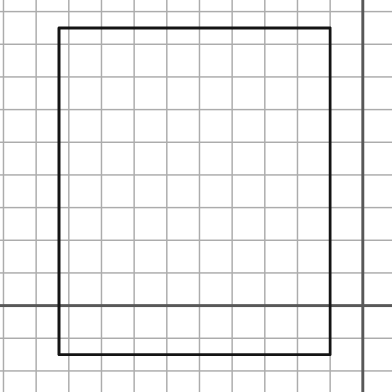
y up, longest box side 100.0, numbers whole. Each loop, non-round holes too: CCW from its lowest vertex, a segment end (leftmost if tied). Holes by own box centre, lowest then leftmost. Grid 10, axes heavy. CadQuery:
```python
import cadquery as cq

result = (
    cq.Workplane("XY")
    .moveTo(-93.0, -15.0)
    .lineTo(-10.0, -15.0)
    .lineTo(-10.0, 85.0)
    .lineTo(-93.0, 85.0)
    .close()
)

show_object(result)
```